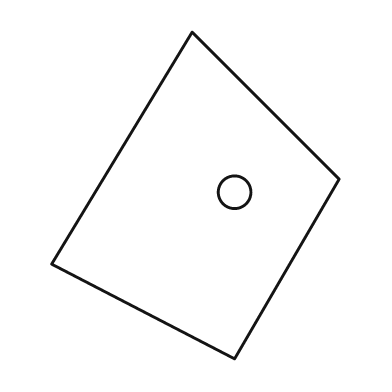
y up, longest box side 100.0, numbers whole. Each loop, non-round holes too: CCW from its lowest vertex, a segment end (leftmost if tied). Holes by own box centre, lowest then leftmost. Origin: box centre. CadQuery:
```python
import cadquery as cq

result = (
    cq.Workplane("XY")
    .moveTo(12.0, -50.0)
    .lineTo(44.0, 5.0)
    .lineTo(-1.0, 50.0)
    .lineTo(-44.0, -21.0)
    .close()
    .moveTo(12.0, 1.0)
    .circle(5.0)
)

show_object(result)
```